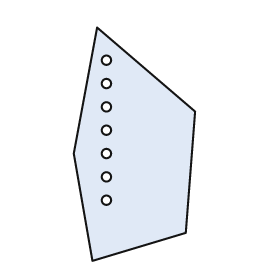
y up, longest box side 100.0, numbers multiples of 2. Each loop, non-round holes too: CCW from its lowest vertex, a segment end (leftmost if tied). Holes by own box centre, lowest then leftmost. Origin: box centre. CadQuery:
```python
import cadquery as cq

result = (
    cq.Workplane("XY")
    .moveTo(-18.0, -50.0)
    .lineTo(22.0, -38.0)
    .lineTo(26.0, 14.0)
    .lineTo(-16.0, 50.0)
    .lineTo(-26.0, -4.0)
    .close()
    .moveTo(-12.0, -24.0)
    .circle(2.0)
    .moveTo(-12.0, -14.0)
    .circle(2.0)
    .moveTo(-12.0, -4.0)
    .circle(2.0)
    .moveTo(-12.0, 6.0)
    .circle(2.0)
    .moveTo(-12.0, 16.0)
    .circle(2.0)
    .moveTo(-12.0, 26.0)
    .circle(2.0)
    .moveTo(-12.0, 36.0)
    .circle(2.0)
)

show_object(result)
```